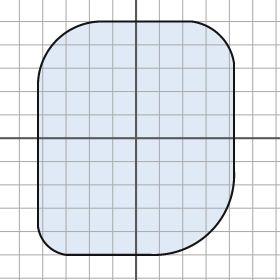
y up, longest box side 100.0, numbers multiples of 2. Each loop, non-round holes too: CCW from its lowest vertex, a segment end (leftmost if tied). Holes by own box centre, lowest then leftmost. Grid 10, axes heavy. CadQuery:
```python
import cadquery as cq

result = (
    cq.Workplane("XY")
    .moveTo(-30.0, -50.0)
    .lineTo(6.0, -50.0)
    .threePointArc((32.0, -40.0), (42.0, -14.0))
    .lineTo(42.0, 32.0)
    .threePointArc((36.0, 44.0), (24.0, 50.0))
    .lineTo(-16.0, 50.0)
    .threePointArc((-34.0, 42.0), (-42.0, 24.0))
    .lineTo(-42.0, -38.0)
    .threePointArc((-38.0, -46.0), (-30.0, -50.0))
    .close()
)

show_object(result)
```